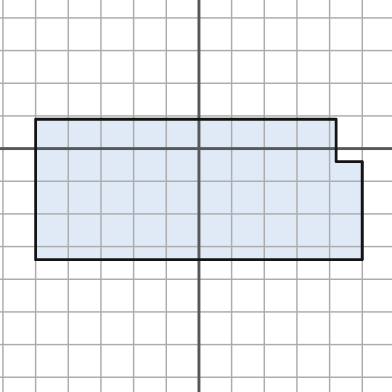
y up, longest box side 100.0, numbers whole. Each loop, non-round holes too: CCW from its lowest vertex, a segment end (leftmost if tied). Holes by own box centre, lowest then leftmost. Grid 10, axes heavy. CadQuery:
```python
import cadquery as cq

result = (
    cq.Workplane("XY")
    .moveTo(-50.0, -34.0)
    .lineTo(50.0, -34.0)
    .lineTo(50.0, -4.0)
    .lineTo(42.0, -4.0)
    .lineTo(42.0, 9.0)
    .lineTo(-50.0, 9.0)
    .close()
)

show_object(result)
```